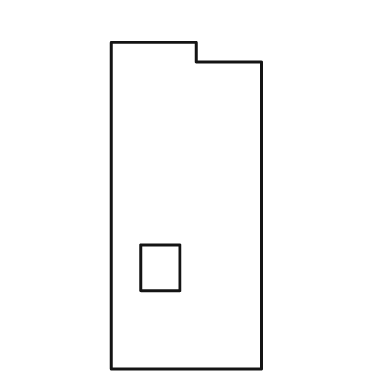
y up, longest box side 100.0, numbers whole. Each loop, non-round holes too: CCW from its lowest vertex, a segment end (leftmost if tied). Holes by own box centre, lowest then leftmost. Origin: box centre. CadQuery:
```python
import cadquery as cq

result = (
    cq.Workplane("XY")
    .moveTo(-23.0, -50.0)
    .lineTo(23.0, -50.0)
    .lineTo(23.0, 44.0)
    .lineTo(3.0, 44.0)
    .lineTo(3.0, 50.0)
    .lineTo(-23.0, 50.0)
    .close()
    .moveTo(-14.0, -26.0)
    .lineTo(-2.0, -26.0)
    .lineTo(-2.0, -12.0)
    .lineTo(-14.0, -12.0)
    .close()
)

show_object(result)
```